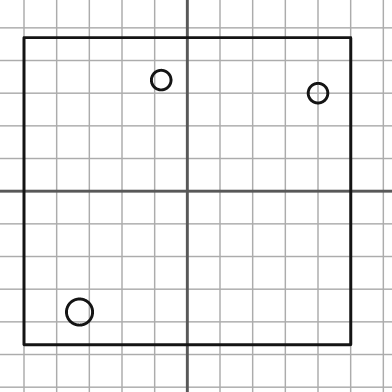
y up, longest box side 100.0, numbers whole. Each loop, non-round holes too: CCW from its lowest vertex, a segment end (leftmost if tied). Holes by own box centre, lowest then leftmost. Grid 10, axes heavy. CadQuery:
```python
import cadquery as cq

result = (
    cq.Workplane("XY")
    .moveTo(-50.0, -47.0)
    .lineTo(50.0, -47.0)
    .lineTo(50.0, 47.0)
    .lineTo(-50.0, 47.0)
    .close()
    .moveTo(-33.0, -37.0)
    .circle(4.0)
    .moveTo(40.0, 30.0)
    .circle(3.0)
    .moveTo(-8.0, 34.0)
    .circle(3.0)
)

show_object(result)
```